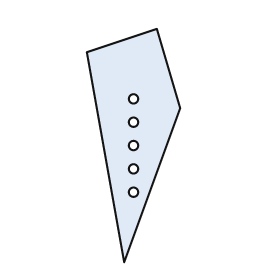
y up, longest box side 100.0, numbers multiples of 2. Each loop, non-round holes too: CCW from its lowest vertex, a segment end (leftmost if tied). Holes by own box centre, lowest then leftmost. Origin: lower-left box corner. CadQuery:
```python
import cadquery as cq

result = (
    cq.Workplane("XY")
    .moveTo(16.0, 0.0)
    .lineTo(40.0, 66.0)
    .lineTo(30.0, 100.0)
    .lineTo(0.0, 90.0)
    .close()
    .moveTo(20.0, 30.0)
    .circle(2.0)
    .moveTo(20.0, 40.0)
    .circle(2.0)
    .moveTo(20.0, 50.0)
    .circle(2.0)
    .moveTo(20.0, 60.0)
    .circle(2.0)
    .moveTo(20.0, 70.0)
    .circle(2.0)
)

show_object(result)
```